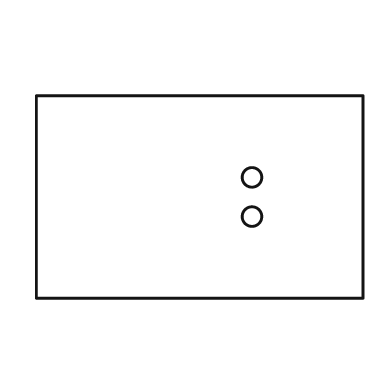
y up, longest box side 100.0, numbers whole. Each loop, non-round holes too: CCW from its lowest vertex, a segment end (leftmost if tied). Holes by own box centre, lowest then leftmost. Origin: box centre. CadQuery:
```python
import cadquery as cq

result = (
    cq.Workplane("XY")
    .moveTo(-50.0, -31.0)
    .lineTo(50.0, -31.0)
    .lineTo(50.0, 31.0)
    .lineTo(-50.0, 31.0)
    .close()
    .moveTo(16.0, -6.0)
    .circle(3.0)
    .moveTo(16.0, 6.0)
    .circle(3.0)
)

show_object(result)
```